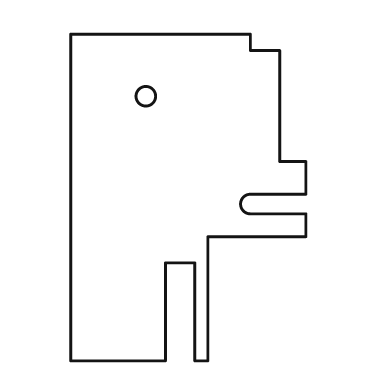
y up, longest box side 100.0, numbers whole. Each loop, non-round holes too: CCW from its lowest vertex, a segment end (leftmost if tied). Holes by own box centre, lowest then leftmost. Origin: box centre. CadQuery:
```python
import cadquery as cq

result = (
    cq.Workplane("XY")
    .moveTo(-36.0, -50.0)
    .lineTo(-7.0, -50.0)
    .lineTo(-7.0, -20.0)
    .lineTo(2.0, -20.0)
    .lineTo(2.0, -50.0)
    .lineTo(6.0, -50.0)
    .lineTo(6.0, -12.0)
    .lineTo(36.0, -12.0)
    .lineTo(36.0, -5.0)
    .lineTo(19.0, -5.0)
    .threePointArc((16.0, -2.0), (19.0, 1.0))
    .lineTo(36.0, 1.0)
    .lineTo(36.0, 11.0)
    .lineTo(28.0, 11.0)
    .lineTo(28.0, 45.0)
    .lineTo(19.0, 45.0)
    .lineTo(19.0, 50.0)
    .lineTo(-36.0, 50.0)
    .close()
    .moveTo(-13.0, 31.0)
    .circle(3.0)
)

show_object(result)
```